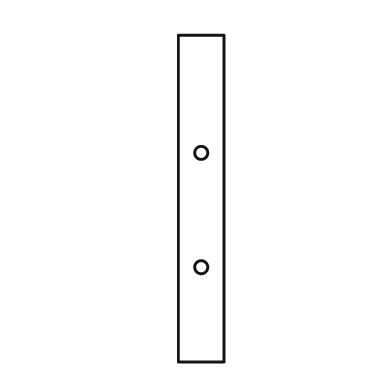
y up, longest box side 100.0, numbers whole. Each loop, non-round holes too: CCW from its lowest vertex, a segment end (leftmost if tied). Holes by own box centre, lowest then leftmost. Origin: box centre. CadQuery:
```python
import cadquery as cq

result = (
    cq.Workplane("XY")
    .moveTo(-7.0, -50.0)
    .lineTo(7.0, -50.0)
    .lineTo(7.0, 50.0)
    .lineTo(-7.0, 50.0)
    .close()
    .moveTo(0.0, -21.0)
    .circle(2.0)
    .moveTo(0.0, 14.0)
    .circle(2.0)
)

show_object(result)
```